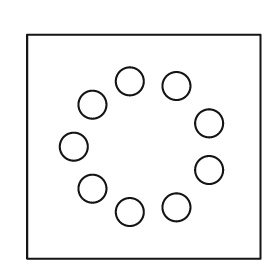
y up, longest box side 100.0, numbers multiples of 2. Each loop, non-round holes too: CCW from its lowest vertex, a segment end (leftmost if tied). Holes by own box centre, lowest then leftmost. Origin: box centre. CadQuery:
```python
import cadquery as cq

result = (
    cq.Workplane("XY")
    .moveTo(-50.0, -48.0)
    .lineTo(50.0, -48.0)
    .lineTo(50.0, 48.0)
    .lineTo(-50.0, 48.0)
    .close()
    .moveTo(-6.0, -28.0)
    .circle(6.0)
    .moveTo(14.0, -26.0)
    .circle(6.0)
    .moveTo(-22.0, -18.0)
    .circle(6.0)
    .moveTo(28.0, -10.0)
    .circle(6.0)
    .moveTo(-30.0, 0.0)
    .circle(6.0)
    .moveTo(28.0, 10.0)
    .circle(6.0)
    .moveTo(-22.0, 18.0)
    .circle(6.0)
    .moveTo(14.0, 26.0)
    .circle(6.0)
    .moveTo(-6.0, 28.0)
    .circle(6.0)
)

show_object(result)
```